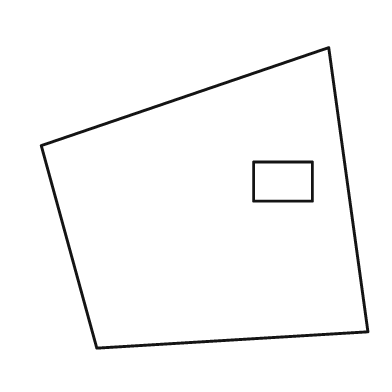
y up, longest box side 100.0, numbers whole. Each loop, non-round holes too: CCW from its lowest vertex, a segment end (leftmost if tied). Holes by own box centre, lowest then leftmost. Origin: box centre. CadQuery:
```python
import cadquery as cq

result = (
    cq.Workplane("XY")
    .moveTo(-33.0, -46.0)
    .lineTo(50.0, -41.0)
    .lineTo(38.0, 46.0)
    .lineTo(-50.0, 16.0)
    .close()
    .moveTo(15.0, -1.0)
    .lineTo(33.0, -1.0)
    .lineTo(33.0, 11.0)
    .lineTo(15.0, 11.0)
    .close()
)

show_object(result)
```